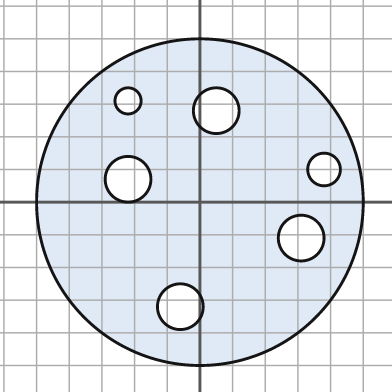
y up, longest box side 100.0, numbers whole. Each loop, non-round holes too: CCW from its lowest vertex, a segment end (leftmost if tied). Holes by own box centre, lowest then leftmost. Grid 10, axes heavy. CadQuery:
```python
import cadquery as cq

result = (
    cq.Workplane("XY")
    .moveTo(0.0, 0.0)
    .circle(50.0)
    .moveTo(-6.0, -32.0)
    .circle(7.0)
    .moveTo(31.0, -11.0)
    .circle(7.0)
    .moveTo(-22.0, 7.0)
    .circle(7.0)
    .moveTo(38.0, 10.0)
    .circle(5.0)
    .moveTo(5.0, 28.0)
    .circle(7.0)
    .moveTo(-22.0, 31.0)
    .circle(4.0)
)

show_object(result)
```